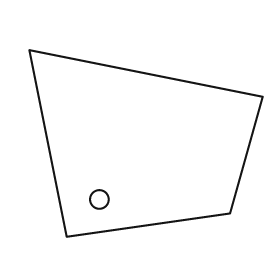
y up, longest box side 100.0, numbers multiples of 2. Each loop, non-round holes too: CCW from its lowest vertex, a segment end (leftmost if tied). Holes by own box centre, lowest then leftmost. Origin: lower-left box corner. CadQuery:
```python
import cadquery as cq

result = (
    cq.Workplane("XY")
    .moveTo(16.0, 0.0)
    .lineTo(86.0, 10.0)
    .lineTo(100.0, 60.0)
    .lineTo(0.0, 80.0)
    .close()
    .moveTo(30.0, 16.0)
    .circle(4.0)
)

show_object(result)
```